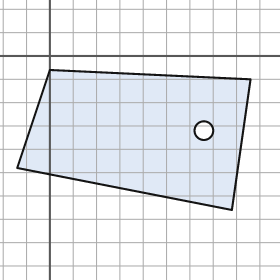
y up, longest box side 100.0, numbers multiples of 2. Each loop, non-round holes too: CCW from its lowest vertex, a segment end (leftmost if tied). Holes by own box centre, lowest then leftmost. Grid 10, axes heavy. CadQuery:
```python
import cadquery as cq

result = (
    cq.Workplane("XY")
    .moveTo(78.0, -66.0)
    .lineTo(86.0, -10.0)
    .lineTo(0.0, -6.0)
    .lineTo(-14.0, -48.0)
    .close()
    .moveTo(66.0, -32.0)
    .circle(4.0)
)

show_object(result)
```